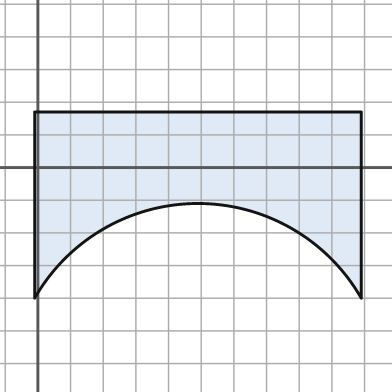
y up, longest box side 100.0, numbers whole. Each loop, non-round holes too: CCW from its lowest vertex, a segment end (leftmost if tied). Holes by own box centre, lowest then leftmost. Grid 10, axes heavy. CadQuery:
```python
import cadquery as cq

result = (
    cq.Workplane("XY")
    .moveTo(-1.0, -40.0)
    .threePointArc((49.0, -11.0), (99.0, -40.0))
    .lineTo(99.0, 17.0)
    .lineTo(-1.0, 17.0)
    .close()
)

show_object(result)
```